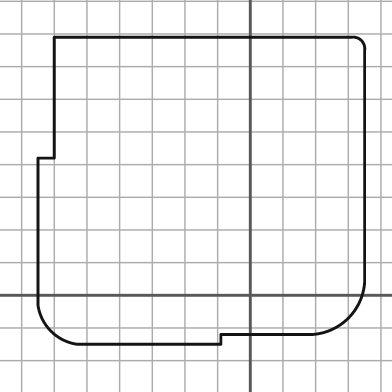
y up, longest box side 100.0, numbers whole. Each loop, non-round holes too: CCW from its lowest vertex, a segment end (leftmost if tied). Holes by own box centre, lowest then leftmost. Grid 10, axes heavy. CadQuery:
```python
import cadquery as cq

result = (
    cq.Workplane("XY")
    .moveTo(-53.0, -15.0)
    .lineTo(-9.0, -15.0)
    .lineTo(-9.0, -12.0)
    .lineTo(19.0, -12.0)
    .threePointArc((30.0, -7.0), (35.0, 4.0))
    .lineTo(35.0, 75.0)
    .threePointArc((34.0, 78.0), (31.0, 79.0))
    .lineTo(-60.0, 79.0)
    .lineTo(-60.0, 42.0)
    .lineTo(-65.0, 42.0)
    .lineTo(-65.0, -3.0)
    .threePointArc((-61.0, -11.0), (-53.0, -15.0))
    .close()
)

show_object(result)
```